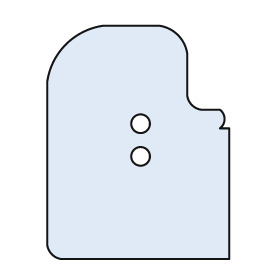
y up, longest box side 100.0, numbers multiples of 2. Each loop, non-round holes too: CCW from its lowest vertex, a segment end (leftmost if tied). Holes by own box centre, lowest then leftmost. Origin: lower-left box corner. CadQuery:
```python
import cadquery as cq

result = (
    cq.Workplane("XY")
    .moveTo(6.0, 0.0)
    .lineTo(78.0, 0.0)
    .lineTo(78.0, 56.0)
    .lineTo(74.0, 56.0)
    .threePointArc((76.0, 60.0), (74.0, 64.0))
    .lineTo(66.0, 64.0)
    .threePointArc((62.0, 66.0), (60.0, 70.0))
    .lineTo(60.0, 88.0)
    .threePointArc((56.0, 96.0), (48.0, 100.0))
    .lineTo(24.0, 100.0)
    .threePointArc((8.0, 92.0), (0.0, 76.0))
    .lineTo(0.0, 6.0)
    .threePointArc((2.0, 2.0), (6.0, 0.0))
    .close()
    .moveTo(40.0, 44.0)
    .circle(4.0)
    .moveTo(40.0, 58.0)
    .circle(4.0)
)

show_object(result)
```